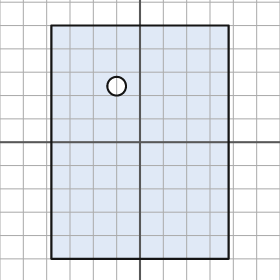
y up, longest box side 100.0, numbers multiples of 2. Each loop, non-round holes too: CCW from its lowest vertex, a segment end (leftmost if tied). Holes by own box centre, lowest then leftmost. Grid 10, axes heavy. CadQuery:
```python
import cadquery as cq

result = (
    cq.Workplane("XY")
    .moveTo(-38.0, -50.0)
    .lineTo(38.0, -50.0)
    .lineTo(38.0, 50.0)
    .lineTo(-38.0, 50.0)
    .close()
    .moveTo(-10.0, 24.0)
    .circle(4.0)
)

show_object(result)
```